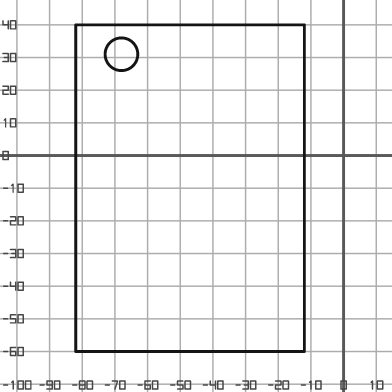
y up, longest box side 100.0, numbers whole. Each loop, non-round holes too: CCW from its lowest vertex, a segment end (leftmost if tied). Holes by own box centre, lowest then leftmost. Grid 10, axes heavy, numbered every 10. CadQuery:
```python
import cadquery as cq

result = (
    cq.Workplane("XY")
    .moveTo(-82.0, -60.0)
    .lineTo(-12.0, -60.0)
    .lineTo(-12.0, 40.0)
    .lineTo(-82.0, 40.0)
    .close()
    .moveTo(-68.0, 31.0)
    .circle(5.0)
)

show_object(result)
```